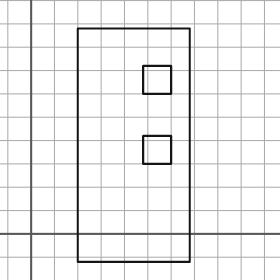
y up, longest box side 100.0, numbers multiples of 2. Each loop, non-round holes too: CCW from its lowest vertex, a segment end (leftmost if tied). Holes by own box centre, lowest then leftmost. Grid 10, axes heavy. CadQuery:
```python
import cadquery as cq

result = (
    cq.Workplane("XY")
    .moveTo(20.0, -12.0)
    .lineTo(68.0, -12.0)
    .lineTo(68.0, 88.0)
    .lineTo(20.0, 88.0)
    .close()
    .moveTo(48.0, 30.0)
    .lineTo(60.0, 30.0)
    .lineTo(60.0, 42.0)
    .lineTo(48.0, 42.0)
    .close()
    .moveTo(48.0, 60.0)
    .lineTo(60.0, 60.0)
    .lineTo(60.0, 72.0)
    .lineTo(48.0, 72.0)
    .close()
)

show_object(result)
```